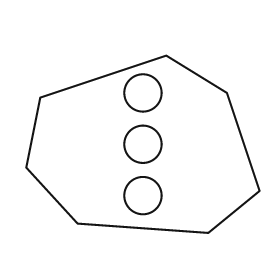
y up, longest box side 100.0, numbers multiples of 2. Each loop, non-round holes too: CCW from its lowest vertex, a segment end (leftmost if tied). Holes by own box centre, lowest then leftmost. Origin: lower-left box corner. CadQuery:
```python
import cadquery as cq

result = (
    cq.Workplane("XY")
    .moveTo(78.0, 0.0)
    .lineTo(100.0, 18.0)
    .lineTo(86.0, 60.0)
    .lineTo(60.0, 76.0)
    .lineTo(6.0, 58.0)
    .lineTo(0.0, 28.0)
    .lineTo(22.0, 4.0)
    .close()
    .moveTo(50.0, 16.0)
    .circle(8.0)
    .moveTo(50.0, 38.0)
    .circle(8.0)
    .moveTo(50.0, 60.0)
    .circle(8.0)
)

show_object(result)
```